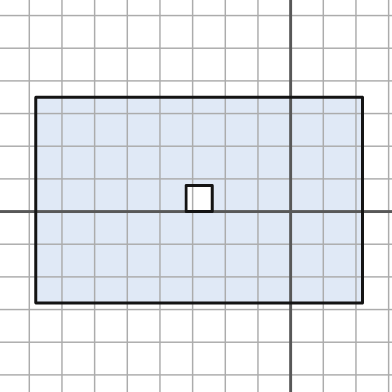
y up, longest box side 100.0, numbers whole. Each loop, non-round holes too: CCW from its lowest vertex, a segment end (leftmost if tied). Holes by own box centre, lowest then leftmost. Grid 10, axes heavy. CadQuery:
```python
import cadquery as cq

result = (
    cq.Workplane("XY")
    .moveTo(-78.0, -28.0)
    .lineTo(22.0, -28.0)
    .lineTo(22.0, 35.0)
    .lineTo(-78.0, 35.0)
    .close()
    .moveTo(-32.0, 0.0)
    .lineTo(-24.0, 0.0)
    .lineTo(-24.0, 8.0)
    .lineTo(-32.0, 8.0)
    .close()
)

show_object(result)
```